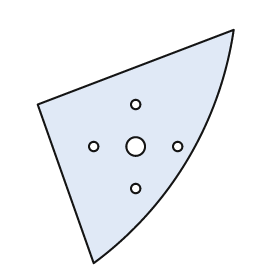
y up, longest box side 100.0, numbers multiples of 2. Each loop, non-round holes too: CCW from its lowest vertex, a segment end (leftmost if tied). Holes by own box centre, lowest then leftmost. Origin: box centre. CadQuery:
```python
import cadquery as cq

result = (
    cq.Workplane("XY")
    .moveTo(-18.0, -50.0)
    .threePointArc((22.0, -6.0), (42.0, 50.0))
    .lineTo(-42.0, 18.0)
    .close()
    .moveTo(0.0, -18.0)
    .circle(2.0)
    .moveTo(-18.0, 0.0)
    .circle(2.0)
    .moveTo(0.0, 0.0)
    .circle(4.0)
    .moveTo(18.0, 0.0)
    .circle(2.0)
    .moveTo(0.0, 18.0)
    .circle(2.0)
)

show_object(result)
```